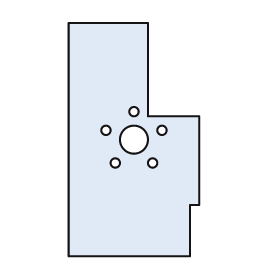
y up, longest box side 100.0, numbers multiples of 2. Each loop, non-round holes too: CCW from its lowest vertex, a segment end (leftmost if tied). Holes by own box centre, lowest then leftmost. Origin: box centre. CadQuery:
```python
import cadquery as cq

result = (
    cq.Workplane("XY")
    .moveTo(-28.0, -50.0)
    .lineTo(24.0, -50.0)
    .lineTo(24.0, -28.0)
    .lineTo(28.0, -28.0)
    .lineTo(28.0, 10.0)
    .lineTo(6.0, 10.0)
    .lineTo(6.0, 50.0)
    .lineTo(-28.0, 50.0)
    .close()
    .moveTo(-8.0, -10.0)
    .circle(2.0)
    .moveTo(8.0, -10.0)
    .circle(2.0)
    .moveTo(0.0, 0.0)
    .circle(6.0)
    .moveTo(-12.0, 4.0)
    .circle(2.0)
    .moveTo(12.0, 4.0)
    .circle(2.0)
    .moveTo(0.0, 12.0)
    .circle(2.0)
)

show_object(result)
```